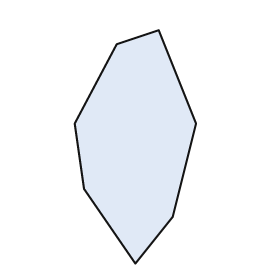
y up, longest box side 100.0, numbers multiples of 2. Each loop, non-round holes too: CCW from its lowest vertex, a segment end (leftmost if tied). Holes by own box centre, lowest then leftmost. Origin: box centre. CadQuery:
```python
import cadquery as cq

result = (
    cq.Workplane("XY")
    .moveTo(0.0, -50.0)
    .lineTo(16.0, -30.0)
    .lineTo(26.0, 10.0)
    .lineTo(10.0, 50.0)
    .lineTo(-8.0, 44.0)
    .lineTo(-26.0, 10.0)
    .lineTo(-22.0, -18.0)
    .close()
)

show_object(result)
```